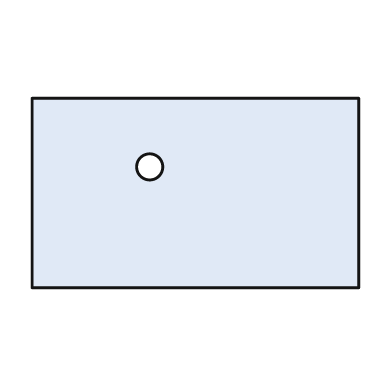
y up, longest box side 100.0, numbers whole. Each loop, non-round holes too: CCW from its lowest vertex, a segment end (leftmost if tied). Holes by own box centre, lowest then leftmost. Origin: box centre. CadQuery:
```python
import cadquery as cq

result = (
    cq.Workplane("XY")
    .moveTo(-50.0, -29.0)
    .lineTo(50.0, -29.0)
    .lineTo(50.0, 29.0)
    .lineTo(-50.0, 29.0)
    .close()
    .moveTo(-14.0, 8.0)
    .circle(4.0)
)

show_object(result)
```